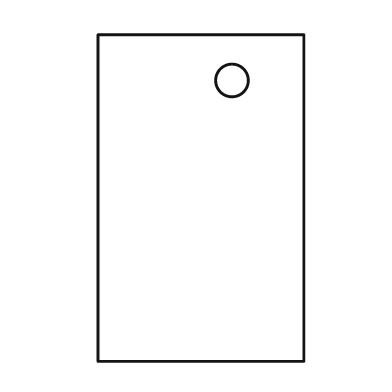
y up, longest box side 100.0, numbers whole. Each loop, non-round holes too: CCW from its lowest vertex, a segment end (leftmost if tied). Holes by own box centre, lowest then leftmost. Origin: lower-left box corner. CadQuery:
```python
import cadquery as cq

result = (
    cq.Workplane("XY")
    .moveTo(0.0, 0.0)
    .lineTo(63.0, 0.0)
    .lineTo(63.0, 100.0)
    .lineTo(0.0, 100.0)
    .close()
    .moveTo(41.0, 86.0)
    .circle(5.0)
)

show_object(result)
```